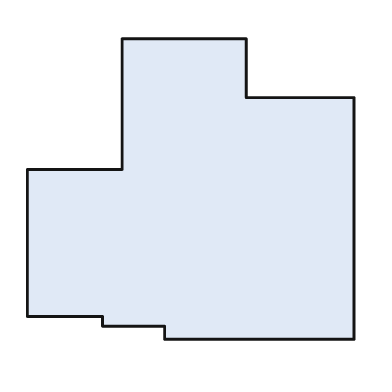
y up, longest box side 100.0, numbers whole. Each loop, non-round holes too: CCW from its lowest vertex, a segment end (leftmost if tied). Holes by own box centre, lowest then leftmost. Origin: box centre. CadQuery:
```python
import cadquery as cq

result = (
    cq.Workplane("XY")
    .moveTo(-8.0, -46.0)
    .lineTo(50.0, -46.0)
    .lineTo(50.0, 28.0)
    .lineTo(17.0, 28.0)
    .lineTo(17.0, 46.0)
    .lineTo(-21.0, 46.0)
    .lineTo(-21.0, 6.0)
    .lineTo(-50.0, 6.0)
    .lineTo(-50.0, -39.0)
    .lineTo(-27.0, -39.0)
    .lineTo(-27.0, -42.0)
    .lineTo(-8.0, -42.0)
    .close()
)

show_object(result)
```